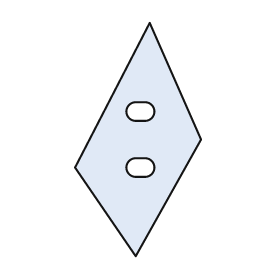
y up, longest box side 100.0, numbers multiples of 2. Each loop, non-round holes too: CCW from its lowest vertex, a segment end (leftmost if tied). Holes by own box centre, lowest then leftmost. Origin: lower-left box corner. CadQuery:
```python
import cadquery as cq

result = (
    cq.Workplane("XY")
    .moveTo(26.0, 0.0)
    .lineTo(54.0, 50.0)
    .lineTo(32.0, 100.0)
    .lineTo(0.0, 38.0)
    .close()
    .moveTo(26.0, 34.0)
    .lineTo(30.0, 34.0)
    .threePointArc((34.0, 38.0), (30.0, 42.0))
    .lineTo(26.0, 42.0)
    .threePointArc((22.0, 38.0), (26.0, 34.0))
    .close()
    .moveTo(26.0, 58.0)
    .lineTo(30.0, 58.0)
    .threePointArc((34.0, 62.0), (30.0, 66.0))
    .lineTo(26.0, 66.0)
    .threePointArc((22.0, 62.0), (26.0, 58.0))
    .close()
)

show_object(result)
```